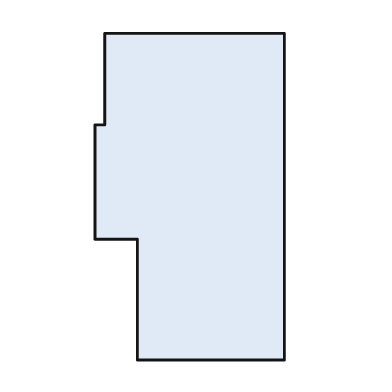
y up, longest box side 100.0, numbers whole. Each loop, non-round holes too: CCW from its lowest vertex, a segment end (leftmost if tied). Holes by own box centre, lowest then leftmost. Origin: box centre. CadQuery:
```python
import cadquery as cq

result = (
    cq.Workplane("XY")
    .moveTo(-16.0, -50.0)
    .lineTo(29.0, -50.0)
    .lineTo(29.0, 50.0)
    .lineTo(-26.0, 50.0)
    .lineTo(-26.0, 22.0)
    .lineTo(-29.0, 22.0)
    .lineTo(-29.0, -13.0)
    .lineTo(-16.0, -13.0)
    .close()
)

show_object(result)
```